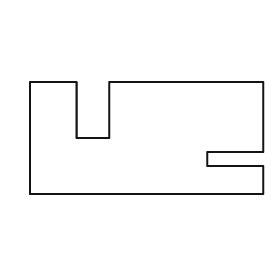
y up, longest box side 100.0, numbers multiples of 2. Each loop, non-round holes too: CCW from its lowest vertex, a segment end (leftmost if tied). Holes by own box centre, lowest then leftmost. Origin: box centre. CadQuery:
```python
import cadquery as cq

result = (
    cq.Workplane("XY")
    .moveTo(-50.0, -24.0)
    .lineTo(50.0, -24.0)
    .lineTo(50.0, -12.0)
    .lineTo(26.0, -12.0)
    .lineTo(26.0, -6.0)
    .lineTo(50.0, -6.0)
    .lineTo(50.0, 24.0)
    .lineTo(-16.0, 24.0)
    .lineTo(-16.0, 0.0)
    .lineTo(-30.0, 0.0)
    .lineTo(-30.0, 24.0)
    .lineTo(-50.0, 24.0)
    .close()
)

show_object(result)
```